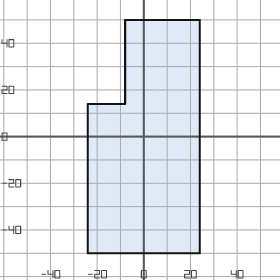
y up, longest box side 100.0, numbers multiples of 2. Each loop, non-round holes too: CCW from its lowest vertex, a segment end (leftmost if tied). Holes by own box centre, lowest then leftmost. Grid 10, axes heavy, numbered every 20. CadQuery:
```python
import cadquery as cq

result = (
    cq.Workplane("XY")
    .moveTo(-24.0, -50.0)
    .lineTo(24.0, -50.0)
    .lineTo(24.0, 50.0)
    .lineTo(-8.0, 50.0)
    .lineTo(-8.0, 14.0)
    .lineTo(-24.0, 14.0)
    .close()
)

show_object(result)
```